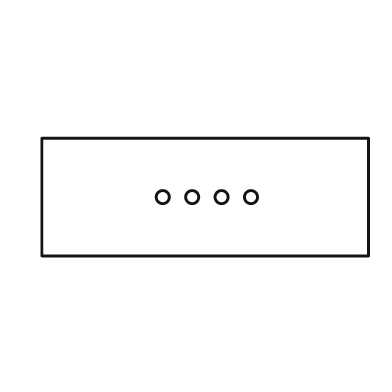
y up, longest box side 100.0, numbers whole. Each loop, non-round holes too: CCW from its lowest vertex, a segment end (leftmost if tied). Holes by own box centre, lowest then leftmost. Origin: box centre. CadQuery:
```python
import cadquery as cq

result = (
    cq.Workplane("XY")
    .moveTo(-50.0, -18.0)
    .lineTo(50.0, -18.0)
    .lineTo(50.0, 18.0)
    .lineTo(-50.0, 18.0)
    .close()
    .moveTo(-13.0, 0.0)
    .circle(2.0)
    .moveTo(-4.0, 0.0)
    .circle(2.0)
    .moveTo(5.0, 0.0)
    .circle(2.0)
    .moveTo(14.0, 0.0)
    .circle(2.0)
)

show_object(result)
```